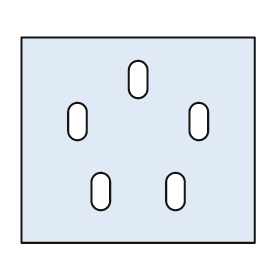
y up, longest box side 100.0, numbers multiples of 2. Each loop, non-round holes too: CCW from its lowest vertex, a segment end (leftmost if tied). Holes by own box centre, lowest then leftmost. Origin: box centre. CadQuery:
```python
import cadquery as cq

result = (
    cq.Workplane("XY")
    .moveTo(-50.0, -44.0)
    .lineTo(50.0, -44.0)
    .lineTo(50.0, 44.0)
    .lineTo(-50.0, 44.0)
    .close()
    .moveTo(-20.0, -26.0)
    .threePointArc((-16.0, -30.0), (-12.0, -26.0))
    .lineTo(-12.0, -18.0)
    .threePointArc((-16.0, -14.0), (-20.0, -18.0))
    .close()
    .moveTo(12.0, -26.0)
    .threePointArc((16.0, -30.0), (20.0, -26.0))
    .lineTo(20.0, -18.0)
    .threePointArc((16.0, -14.0), (12.0, -18.0))
    .close()
    .moveTo(-30.0, 4.0)
    .threePointArc((-26.0, 0.0), (-22.0, 4.0))
    .lineTo(-22.0, 12.0)
    .threePointArc((-26.0, 16.0), (-30.0, 12.0))
    .close()
    .moveTo(22.0, 4.0)
    .threePointArc((26.0, 0.0), (30.0, 4.0))
    .lineTo(30.0, 12.0)
    .threePointArc((26.0, 16.0), (22.0, 12.0))
    .close()
    .moveTo(-4.0, 22.0)
    .threePointArc((0.0, 18.0), (4.0, 22.0))
    .lineTo(4.0, 30.0)
    .threePointArc((0.0, 34.0), (-4.0, 30.0))
    .close()
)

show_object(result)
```